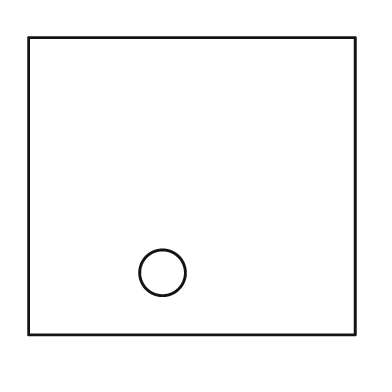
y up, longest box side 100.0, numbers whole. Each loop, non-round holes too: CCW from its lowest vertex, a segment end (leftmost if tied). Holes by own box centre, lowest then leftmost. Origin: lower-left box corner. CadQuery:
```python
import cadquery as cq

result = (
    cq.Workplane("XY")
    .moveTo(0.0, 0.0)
    .lineTo(100.0, 0.0)
    .lineTo(100.0, 91.0)
    .lineTo(0.0, 91.0)
    .close()
    .moveTo(41.0, 19.0)
    .circle(7.0)
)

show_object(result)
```